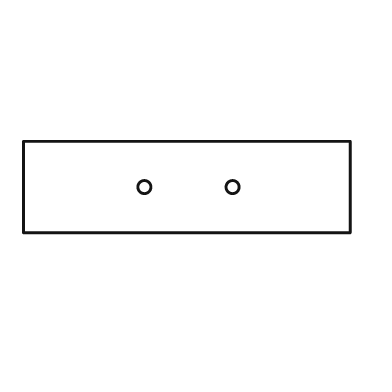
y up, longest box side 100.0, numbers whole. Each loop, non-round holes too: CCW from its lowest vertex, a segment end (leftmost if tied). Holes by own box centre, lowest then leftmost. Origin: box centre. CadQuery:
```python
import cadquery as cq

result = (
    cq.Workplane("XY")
    .moveTo(-50.0, -14.0)
    .lineTo(50.0, -14.0)
    .lineTo(50.0, 14.0)
    .lineTo(-50.0, 14.0)
    .close()
    .moveTo(-13.0, 0.0)
    .circle(2.0)
    .moveTo(14.0, 0.0)
    .circle(2.0)
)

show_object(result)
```